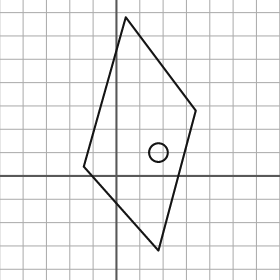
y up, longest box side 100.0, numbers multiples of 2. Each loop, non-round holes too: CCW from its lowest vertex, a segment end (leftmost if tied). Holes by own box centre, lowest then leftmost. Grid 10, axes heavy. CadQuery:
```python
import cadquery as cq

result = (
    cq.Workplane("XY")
    .moveTo(18.0, -32.0)
    .lineTo(34.0, 28.0)
    .lineTo(4.0, 68.0)
    .lineTo(-14.0, 4.0)
    .close()
    .moveTo(18.0, 10.0)
    .circle(4.0)
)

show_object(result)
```